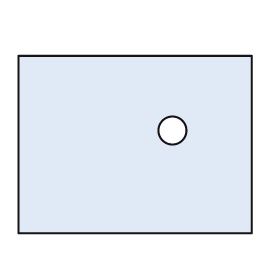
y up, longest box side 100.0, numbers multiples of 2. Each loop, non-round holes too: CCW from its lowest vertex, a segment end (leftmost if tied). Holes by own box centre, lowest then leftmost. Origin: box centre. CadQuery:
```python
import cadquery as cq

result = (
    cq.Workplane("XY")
    .moveTo(-50.0, -38.0)
    .lineTo(50.0, -38.0)
    .lineTo(50.0, 38.0)
    .lineTo(-50.0, 38.0)
    .close()
    .moveTo(16.0, 6.0)
    .circle(6.0)
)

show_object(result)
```